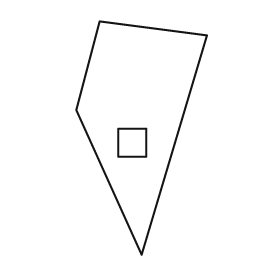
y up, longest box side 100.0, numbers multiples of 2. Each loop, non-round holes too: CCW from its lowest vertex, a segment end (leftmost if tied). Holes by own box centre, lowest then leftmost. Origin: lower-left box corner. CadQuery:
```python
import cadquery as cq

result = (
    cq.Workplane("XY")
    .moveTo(28.0, 0.0)
    .lineTo(56.0, 94.0)
    .lineTo(10.0, 100.0)
    .lineTo(0.0, 62.0)
    .close()
    .moveTo(18.0, 42.0)
    .lineTo(30.0, 42.0)
    .lineTo(30.0, 54.0)
    .lineTo(18.0, 54.0)
    .close()
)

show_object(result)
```